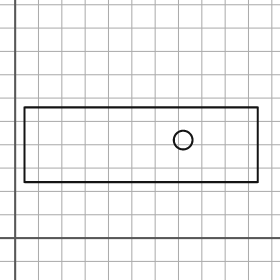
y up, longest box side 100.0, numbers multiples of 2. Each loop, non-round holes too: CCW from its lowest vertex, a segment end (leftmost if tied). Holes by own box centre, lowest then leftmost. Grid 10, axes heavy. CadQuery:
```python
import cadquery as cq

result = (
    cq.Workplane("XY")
    .moveTo(4.0, 24.0)
    .lineTo(104.0, 24.0)
    .lineTo(104.0, 56.0)
    .lineTo(4.0, 56.0)
    .close()
    .moveTo(72.0, 42.0)
    .circle(4.0)
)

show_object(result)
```